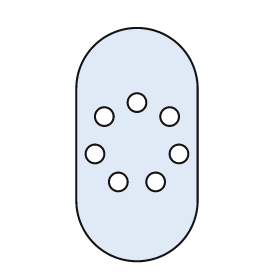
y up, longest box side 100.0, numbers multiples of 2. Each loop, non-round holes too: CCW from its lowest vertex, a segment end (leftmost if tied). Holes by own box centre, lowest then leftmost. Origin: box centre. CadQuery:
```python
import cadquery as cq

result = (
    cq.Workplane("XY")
    .moveTo(-26.0, -24.0)
    .threePointArc((0.0, -50.0), (26.0, -24.0))
    .lineTo(26.0, 24.0)
    .threePointArc((0.0, 50.0), (-26.0, 24.0))
    .close()
    .moveTo(-8.0, -16.0)
    .circle(4.0)
    .moveTo(8.0, -16.0)
    .circle(4.0)
    .moveTo(-18.0, -4.0)
    .circle(4.0)
    .moveTo(18.0, -4.0)
    .circle(4.0)
    .moveTo(-14.0, 12.0)
    .circle(4.0)
    .moveTo(14.0, 12.0)
    .circle(4.0)
    .moveTo(0.0, 18.0)
    .circle(4.0)
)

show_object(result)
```